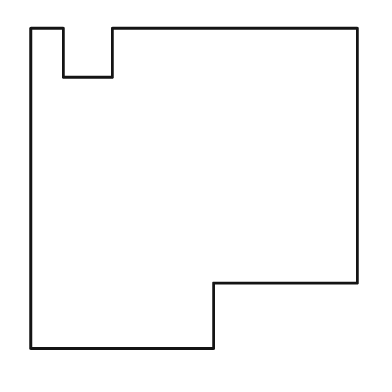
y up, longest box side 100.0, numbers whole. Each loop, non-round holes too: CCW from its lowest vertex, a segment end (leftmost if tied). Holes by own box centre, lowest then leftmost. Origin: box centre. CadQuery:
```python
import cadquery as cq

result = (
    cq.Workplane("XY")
    .moveTo(-50.0, -49.0)
    .lineTo(6.0, -49.0)
    .lineTo(6.0, -29.0)
    .lineTo(50.0, -29.0)
    .lineTo(50.0, 49.0)
    .lineTo(-25.0, 49.0)
    .lineTo(-25.0, 34.0)
    .lineTo(-40.0, 34.0)
    .lineTo(-40.0, 49.0)
    .lineTo(-50.0, 49.0)
    .close()
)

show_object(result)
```